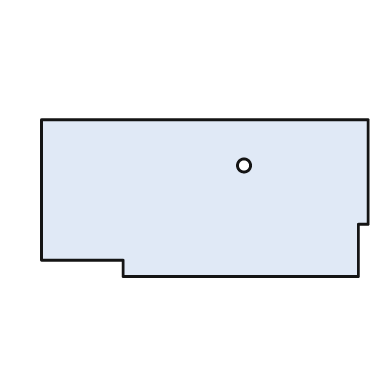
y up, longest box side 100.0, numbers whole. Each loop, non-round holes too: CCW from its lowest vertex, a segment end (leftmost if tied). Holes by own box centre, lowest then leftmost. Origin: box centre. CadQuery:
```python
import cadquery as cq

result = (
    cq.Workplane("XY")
    .moveTo(-25.0, -24.0)
    .lineTo(47.0, -24.0)
    .lineTo(47.0, -8.0)
    .lineTo(50.0, -8.0)
    .lineTo(50.0, 24.0)
    .lineTo(-50.0, 24.0)
    .lineTo(-50.0, -19.0)
    .lineTo(-25.0, -19.0)
    .close()
    .moveTo(12.0, 10.0)
    .circle(2.0)
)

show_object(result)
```